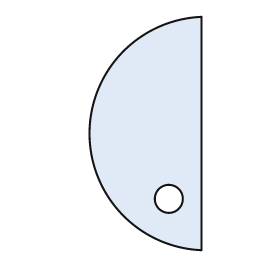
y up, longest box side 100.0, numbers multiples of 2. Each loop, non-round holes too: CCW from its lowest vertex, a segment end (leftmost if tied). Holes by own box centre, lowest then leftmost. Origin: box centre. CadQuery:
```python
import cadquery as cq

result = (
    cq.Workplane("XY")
    .moveTo(24.0, -50.0)
    .lineTo(24.0, 50.0)
    .threePointArc((-24.0, 0.0), (24.0, -50.0))
    .close()
    .moveTo(10.0, -28.0)
    .circle(6.0)
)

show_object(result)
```